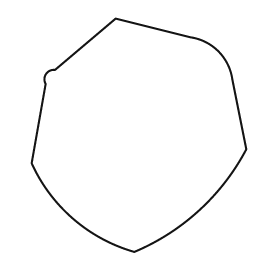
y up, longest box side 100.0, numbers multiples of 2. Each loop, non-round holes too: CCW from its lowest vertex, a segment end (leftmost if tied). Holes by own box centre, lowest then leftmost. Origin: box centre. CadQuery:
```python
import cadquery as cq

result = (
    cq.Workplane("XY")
    .moveTo(-2.0, -50.0)
    .threePointArc((26.0, -32.0), (46.0, -6.0))
    .lineTo(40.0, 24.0)
    .threePointArc((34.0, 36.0), (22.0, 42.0))
    .lineTo(-10.0, 50.0)
    .lineTo(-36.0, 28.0)
    .threePointArc((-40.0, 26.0), (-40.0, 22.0))
    .lineTo(-46.0, -12.0)
    .threePointArc((-28.0, -36.0), (-2.0, -50.0))
    .close()
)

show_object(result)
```